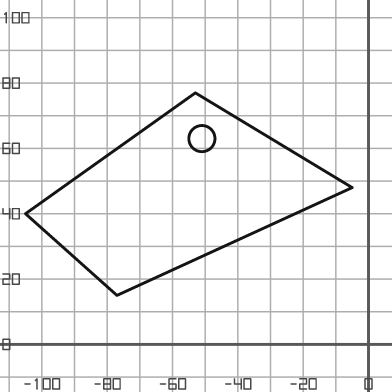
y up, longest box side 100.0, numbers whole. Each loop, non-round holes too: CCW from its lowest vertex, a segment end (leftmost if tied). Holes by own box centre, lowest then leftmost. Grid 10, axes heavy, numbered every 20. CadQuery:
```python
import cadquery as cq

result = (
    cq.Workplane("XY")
    .moveTo(-77.0, 15.0)
    .lineTo(-5.0, 48.0)
    .lineTo(-53.0, 77.0)
    .lineTo(-105.0, 40.0)
    .close()
    .moveTo(-51.0, 63.0)
    .circle(4.0)
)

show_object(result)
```